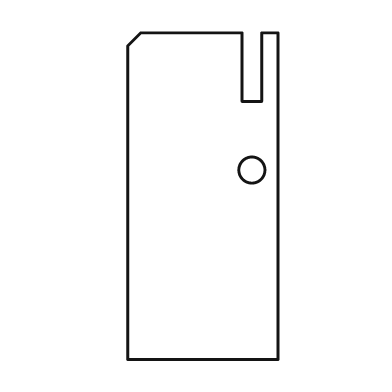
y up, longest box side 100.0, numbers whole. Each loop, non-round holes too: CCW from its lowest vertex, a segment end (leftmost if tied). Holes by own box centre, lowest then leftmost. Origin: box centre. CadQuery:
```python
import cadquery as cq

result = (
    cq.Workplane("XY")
    .moveTo(-23.0, -50.0)
    .lineTo(23.0, -50.0)
    .lineTo(23.0, 50.0)
    .lineTo(18.0, 50.0)
    .lineTo(18.0, 29.0)
    .lineTo(12.0, 29.0)
    .lineTo(12.0, 50.0)
    .lineTo(-19.0, 50.0)
    .lineTo(-23.0, 46.0)
    .close()
    .moveTo(15.0, 8.0)
    .circle(4.0)
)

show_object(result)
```